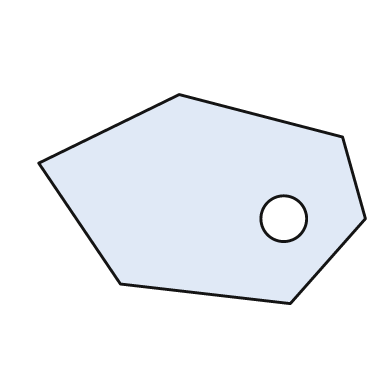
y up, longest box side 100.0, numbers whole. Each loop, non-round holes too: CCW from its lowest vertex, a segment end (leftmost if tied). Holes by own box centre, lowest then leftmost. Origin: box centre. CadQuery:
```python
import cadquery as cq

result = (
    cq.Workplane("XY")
    .moveTo(27.0, -32.0)
    .lineTo(50.0, -6.0)
    .lineTo(43.0, 19.0)
    .lineTo(-7.0, 32.0)
    .lineTo(-50.0, 11.0)
    .lineTo(-25.0, -26.0)
    .close()
    .moveTo(25.0, -6.0)
    .circle(7.0)
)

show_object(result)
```